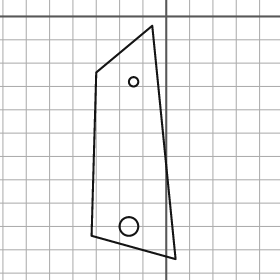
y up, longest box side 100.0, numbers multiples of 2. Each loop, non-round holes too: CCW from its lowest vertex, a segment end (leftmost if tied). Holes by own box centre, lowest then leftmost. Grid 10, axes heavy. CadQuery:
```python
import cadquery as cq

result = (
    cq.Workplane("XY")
    .moveTo(4.0, -104.0)
    .lineTo(-6.0, -4.0)
    .lineTo(-30.0, -24.0)
    .lineTo(-32.0, -94.0)
    .close()
    .moveTo(-16.0, -90.0)
    .circle(4.0)
    .moveTo(-14.0, -28.0)
    .circle(2.0)
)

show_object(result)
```